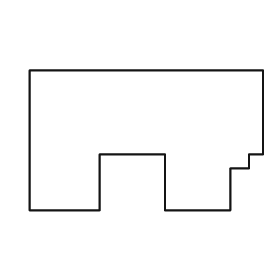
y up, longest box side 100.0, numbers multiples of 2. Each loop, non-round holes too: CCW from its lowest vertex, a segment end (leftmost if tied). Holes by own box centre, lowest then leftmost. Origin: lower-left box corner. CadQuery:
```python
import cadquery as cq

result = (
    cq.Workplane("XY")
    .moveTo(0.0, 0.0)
    .lineTo(30.0, 0.0)
    .lineTo(30.0, 24.0)
    .lineTo(58.0, 24.0)
    .lineTo(58.0, 0.0)
    .lineTo(86.0, 0.0)
    .lineTo(86.0, 18.0)
    .lineTo(94.0, 18.0)
    .lineTo(94.0, 24.0)
    .lineTo(100.0, 24.0)
    .lineTo(100.0, 60.0)
    .lineTo(0.0, 60.0)
    .close()
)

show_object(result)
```